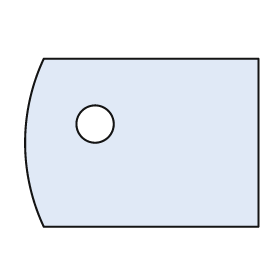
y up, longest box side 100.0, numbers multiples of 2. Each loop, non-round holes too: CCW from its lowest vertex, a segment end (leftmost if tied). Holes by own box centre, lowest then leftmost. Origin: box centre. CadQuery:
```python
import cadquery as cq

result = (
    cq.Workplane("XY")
    .moveTo(-42.0, -36.0)
    .lineTo(50.0, -36.0)
    .lineTo(50.0, 36.0)
    .lineTo(-42.0, 36.0)
    .threePointArc((-50.0, 0.0), (-42.0, -36.0))
    .close()
    .moveTo(-20.0, 8.0)
    .circle(8.0)
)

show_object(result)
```